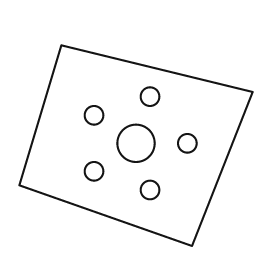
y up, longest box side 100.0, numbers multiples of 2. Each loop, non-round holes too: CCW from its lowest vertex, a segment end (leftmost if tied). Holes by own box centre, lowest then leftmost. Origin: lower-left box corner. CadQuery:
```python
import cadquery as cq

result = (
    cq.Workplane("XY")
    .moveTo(74.0, 0.0)
    .lineTo(100.0, 66.0)
    .lineTo(18.0, 86.0)
    .lineTo(0.0, 26.0)
    .close()
    .moveTo(56.0, 24.0)
    .circle(4.0)
    .moveTo(32.0, 32.0)
    .circle(4.0)
    .moveTo(50.0, 44.0)
    .circle(8.0)
    .moveTo(72.0, 44.0)
    .circle(4.0)
    .moveTo(32.0, 56.0)
    .circle(4.0)
    .moveTo(56.0, 64.0)
    .circle(4.0)
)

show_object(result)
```